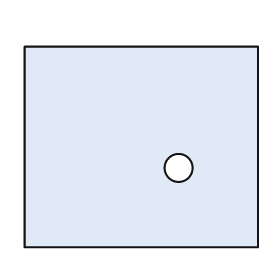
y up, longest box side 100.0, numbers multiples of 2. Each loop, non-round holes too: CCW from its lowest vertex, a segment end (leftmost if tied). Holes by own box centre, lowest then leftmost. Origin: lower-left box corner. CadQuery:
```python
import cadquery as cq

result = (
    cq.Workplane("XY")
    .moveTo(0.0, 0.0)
    .lineTo(100.0, 0.0)
    .lineTo(100.0, 86.0)
    .lineTo(0.0, 86.0)
    .close()
    .moveTo(66.0, 34.0)
    .circle(6.0)
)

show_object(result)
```